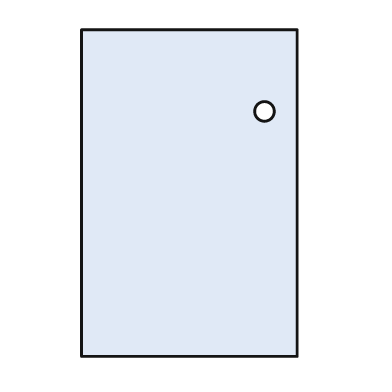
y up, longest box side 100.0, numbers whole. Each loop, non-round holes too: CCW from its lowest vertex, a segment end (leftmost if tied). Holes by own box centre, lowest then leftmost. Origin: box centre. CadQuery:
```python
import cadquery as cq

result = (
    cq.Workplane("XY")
    .moveTo(-33.0, -50.0)
    .lineTo(33.0, -50.0)
    .lineTo(33.0, 50.0)
    .lineTo(-33.0, 50.0)
    .close()
    .moveTo(23.0, 25.0)
    .circle(3.0)
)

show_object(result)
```